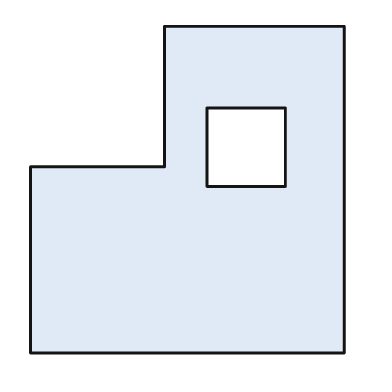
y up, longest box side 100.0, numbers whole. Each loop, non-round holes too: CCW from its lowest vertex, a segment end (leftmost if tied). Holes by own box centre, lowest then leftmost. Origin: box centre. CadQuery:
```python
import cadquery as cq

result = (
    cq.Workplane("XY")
    .moveTo(-48.0, -50.0)
    .lineTo(48.0, -50.0)
    .lineTo(48.0, 50.0)
    .lineTo(-7.0, 50.0)
    .lineTo(-7.0, 7.0)
    .lineTo(-48.0, 7.0)
    .close()
    .moveTo(6.0, 1.0)
    .lineTo(30.0, 1.0)
    .lineTo(30.0, 25.0)
    .lineTo(6.0, 25.0)
    .close()
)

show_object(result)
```